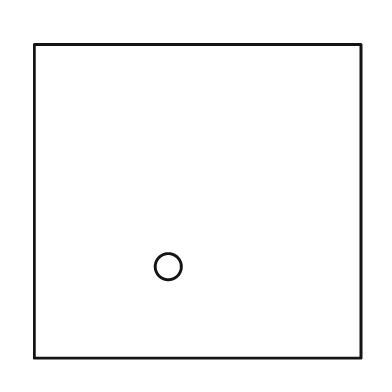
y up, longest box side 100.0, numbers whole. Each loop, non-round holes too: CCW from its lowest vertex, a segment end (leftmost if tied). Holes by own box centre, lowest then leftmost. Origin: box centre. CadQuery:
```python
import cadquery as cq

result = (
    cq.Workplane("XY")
    .moveTo(-50.0, -48.0)
    .lineTo(50.0, -48.0)
    .lineTo(50.0, 48.0)
    .lineTo(-50.0, 48.0)
    .close()
    .moveTo(-9.0, -20.0)
    .circle(4.0)
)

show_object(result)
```